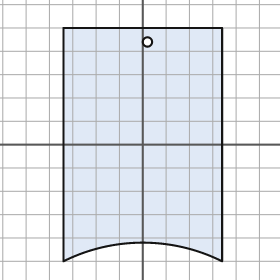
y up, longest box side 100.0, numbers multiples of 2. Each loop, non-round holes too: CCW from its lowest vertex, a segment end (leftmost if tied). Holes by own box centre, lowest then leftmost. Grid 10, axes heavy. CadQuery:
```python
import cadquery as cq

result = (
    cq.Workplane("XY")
    .moveTo(-34.0, -50.0)
    .threePointArc((0.0, -42.0), (34.0, -50.0))
    .lineTo(34.0, 50.0)
    .lineTo(-34.0, 50.0)
    .close()
    .moveTo(2.0, 44.0)
    .circle(2.0)
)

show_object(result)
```